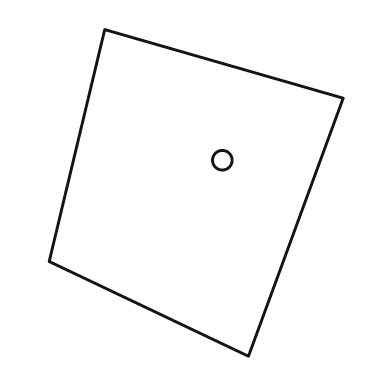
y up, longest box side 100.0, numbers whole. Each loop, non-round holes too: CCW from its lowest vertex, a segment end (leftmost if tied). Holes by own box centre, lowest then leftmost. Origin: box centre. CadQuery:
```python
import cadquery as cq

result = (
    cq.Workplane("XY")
    .moveTo(16.0, -50.0)
    .lineTo(45.0, 29.0)
    .lineTo(-28.0, 50.0)
    .lineTo(-45.0, -21.0)
    .close()
    .moveTo(8.0, 10.0)
    .circle(3.0)
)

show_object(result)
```